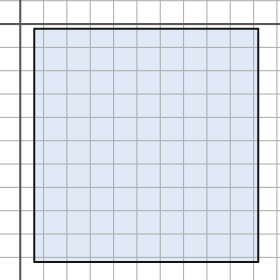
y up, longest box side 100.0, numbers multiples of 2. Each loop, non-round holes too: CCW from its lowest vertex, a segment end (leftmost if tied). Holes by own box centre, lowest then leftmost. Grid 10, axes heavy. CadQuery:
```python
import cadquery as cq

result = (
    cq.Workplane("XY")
    .moveTo(6.0, -102.0)
    .lineTo(102.0, -102.0)
    .lineTo(102.0, -2.0)
    .lineTo(6.0, -2.0)
    .close()
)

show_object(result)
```